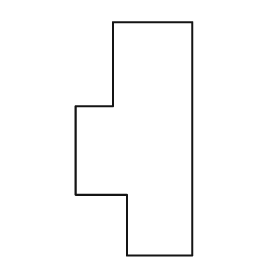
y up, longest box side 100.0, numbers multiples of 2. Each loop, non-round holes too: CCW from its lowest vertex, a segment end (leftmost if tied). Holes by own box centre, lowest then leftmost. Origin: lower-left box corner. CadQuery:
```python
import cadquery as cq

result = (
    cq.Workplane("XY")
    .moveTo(22.0, 0.0)
    .lineTo(50.0, 0.0)
    .lineTo(50.0, 100.0)
    .lineTo(16.0, 100.0)
    .lineTo(16.0, 64.0)
    .lineTo(0.0, 64.0)
    .lineTo(0.0, 26.0)
    .lineTo(22.0, 26.0)
    .close()
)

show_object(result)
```